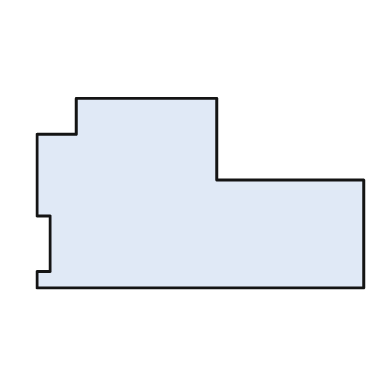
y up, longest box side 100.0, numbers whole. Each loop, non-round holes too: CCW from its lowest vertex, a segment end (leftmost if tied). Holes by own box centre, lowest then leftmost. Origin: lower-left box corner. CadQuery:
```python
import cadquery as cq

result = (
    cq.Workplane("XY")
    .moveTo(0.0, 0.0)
    .lineTo(100.0, 0.0)
    .lineTo(100.0, 33.0)
    .lineTo(55.0, 33.0)
    .lineTo(55.0, 58.0)
    .lineTo(12.0, 58.0)
    .lineTo(12.0, 47.0)
    .lineTo(0.0, 47.0)
    .lineTo(0.0, 22.0)
    .lineTo(4.0, 22.0)
    .lineTo(4.0, 5.0)
    .lineTo(0.0, 5.0)
    .close()
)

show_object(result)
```